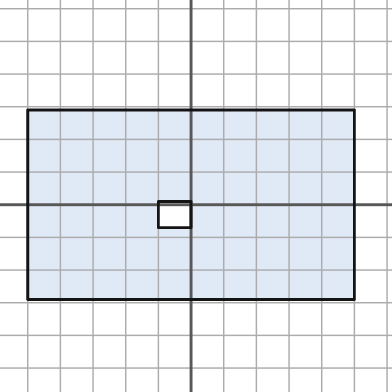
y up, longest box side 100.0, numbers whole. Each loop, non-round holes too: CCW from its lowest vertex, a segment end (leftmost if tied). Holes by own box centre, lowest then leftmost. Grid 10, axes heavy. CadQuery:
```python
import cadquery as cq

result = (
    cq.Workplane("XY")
    .moveTo(-50.0, -29.0)
    .lineTo(50.0, -29.0)
    .lineTo(50.0, 29.0)
    .lineTo(-50.0, 29.0)
    .close()
    .moveTo(-10.0, -7.0)
    .lineTo(0.0, -7.0)
    .lineTo(0.0, 1.0)
    .lineTo(-10.0, 1.0)
    .close()
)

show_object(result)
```